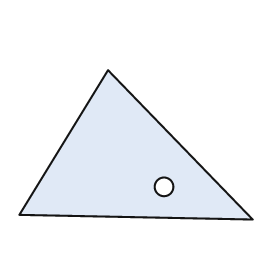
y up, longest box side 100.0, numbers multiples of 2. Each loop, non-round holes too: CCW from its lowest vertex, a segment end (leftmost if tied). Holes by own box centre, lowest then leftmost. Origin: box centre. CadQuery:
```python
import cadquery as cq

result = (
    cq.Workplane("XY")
    .moveTo(50.0, -32.0)
    .lineTo(-12.0, 32.0)
    .lineTo(-50.0, -30.0)
    .close()
    .moveTo(12.0, -18.0)
    .circle(4.0)
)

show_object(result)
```